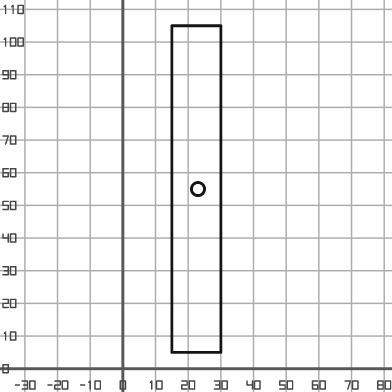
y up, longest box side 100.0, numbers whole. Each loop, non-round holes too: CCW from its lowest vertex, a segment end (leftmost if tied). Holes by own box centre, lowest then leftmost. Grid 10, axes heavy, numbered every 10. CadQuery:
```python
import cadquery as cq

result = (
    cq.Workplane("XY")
    .moveTo(15.0, 5.0)
    .lineTo(30.0, 5.0)
    .lineTo(30.0, 105.0)
    .lineTo(15.0, 105.0)
    .close()
    .moveTo(23.0, 55.0)
    .circle(2.0)
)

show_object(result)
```